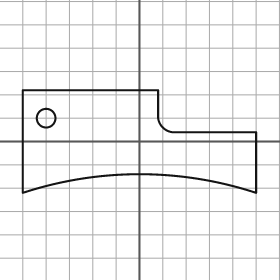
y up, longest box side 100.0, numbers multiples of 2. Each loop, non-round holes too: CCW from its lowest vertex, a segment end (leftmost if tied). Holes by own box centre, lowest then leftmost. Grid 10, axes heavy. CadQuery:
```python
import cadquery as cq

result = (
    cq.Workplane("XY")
    .moveTo(-50.0, -22.0)
    .threePointArc((0.0, -14.0), (50.0, -22.0))
    .lineTo(50.0, 4.0)
    .lineTo(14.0, 4.0)
    .threePointArc((10.0, 6.0), (8.0, 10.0))
    .lineTo(8.0, 22.0)
    .lineTo(-50.0, 22.0)
    .close()
    .moveTo(-40.0, 10.0)
    .circle(4.0)
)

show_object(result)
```